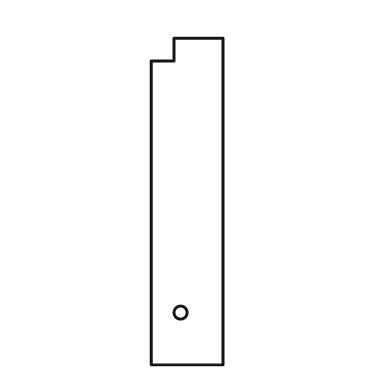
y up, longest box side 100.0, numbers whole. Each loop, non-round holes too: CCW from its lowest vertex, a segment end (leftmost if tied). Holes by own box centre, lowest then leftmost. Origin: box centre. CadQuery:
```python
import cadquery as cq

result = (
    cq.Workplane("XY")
    .moveTo(-11.0, -50.0)
    .lineTo(11.0, -50.0)
    .lineTo(11.0, 50.0)
    .lineTo(-4.0, 50.0)
    .lineTo(-4.0, 43.0)
    .lineTo(-11.0, 43.0)
    .close()
    .moveTo(-2.0, -34.0)
    .circle(2.0)
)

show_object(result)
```